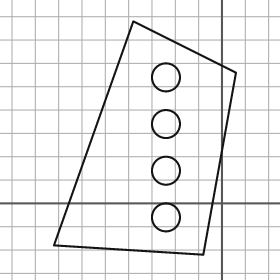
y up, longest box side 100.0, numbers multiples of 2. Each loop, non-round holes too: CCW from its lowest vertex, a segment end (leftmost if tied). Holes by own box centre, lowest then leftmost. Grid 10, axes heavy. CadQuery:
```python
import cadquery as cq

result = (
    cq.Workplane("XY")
    .moveTo(-8.0, -22.0)
    .lineTo(6.0, 56.0)
    .lineTo(-38.0, 78.0)
    .lineTo(-72.0, -18.0)
    .close()
    .moveTo(-24.0, -6.0)
    .circle(6.0)
    .moveTo(-24.0, 14.0)
    .circle(6.0)
    .moveTo(-24.0, 34.0)
    .circle(6.0)
    .moveTo(-24.0, 54.0)
    .circle(6.0)
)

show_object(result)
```